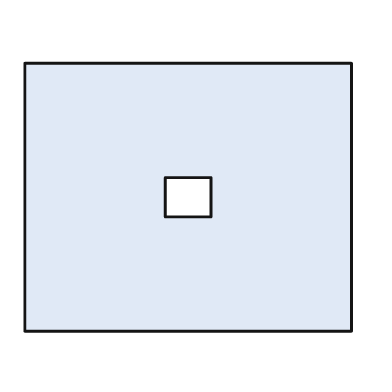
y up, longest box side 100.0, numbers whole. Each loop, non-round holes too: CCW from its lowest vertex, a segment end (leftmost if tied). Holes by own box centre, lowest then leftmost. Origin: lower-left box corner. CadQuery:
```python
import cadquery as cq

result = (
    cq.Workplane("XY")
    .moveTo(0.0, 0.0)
    .lineTo(100.0, 0.0)
    .lineTo(100.0, 82.0)
    .lineTo(0.0, 82.0)
    .close()
    .moveTo(43.0, 35.0)
    .lineTo(57.0, 35.0)
    .lineTo(57.0, 47.0)
    .lineTo(43.0, 47.0)
    .close()
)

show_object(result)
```